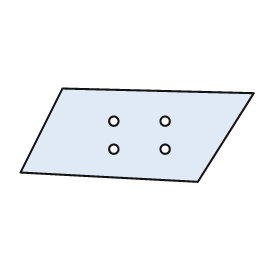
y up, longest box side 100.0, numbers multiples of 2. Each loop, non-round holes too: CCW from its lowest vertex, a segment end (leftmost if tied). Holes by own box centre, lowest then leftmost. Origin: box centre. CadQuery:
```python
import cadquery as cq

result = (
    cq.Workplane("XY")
    .moveTo(26.0, -20.0)
    .lineTo(50.0, 18.0)
    .lineTo(-32.0, 20.0)
    .lineTo(-50.0, -16.0)
    .close()
    .moveTo(-10.0, -6.0)
    .circle(2.0)
    .moveTo(12.0, -6.0)
    .circle(2.0)
    .moveTo(-10.0, 6.0)
    .circle(2.0)
    .moveTo(12.0, 6.0)
    .circle(2.0)
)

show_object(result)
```